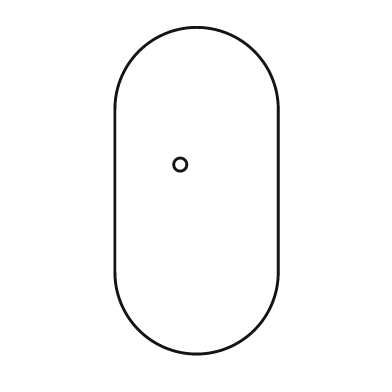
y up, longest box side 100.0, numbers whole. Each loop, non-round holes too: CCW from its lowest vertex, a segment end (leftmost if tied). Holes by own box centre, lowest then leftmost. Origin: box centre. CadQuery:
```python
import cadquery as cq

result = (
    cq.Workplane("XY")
    .moveTo(-25.0, -25.0)
    .threePointArc((0.0, -50.0), (25.0, -25.0))
    .lineTo(25.0, 25.0)
    .threePointArc((0.0, 50.0), (-25.0, 25.0))
    .close()
    .moveTo(-5.0, 8.0)
    .circle(2.0)
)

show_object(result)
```